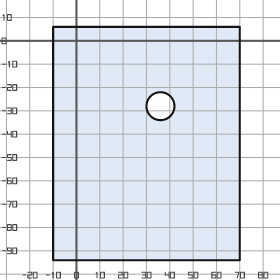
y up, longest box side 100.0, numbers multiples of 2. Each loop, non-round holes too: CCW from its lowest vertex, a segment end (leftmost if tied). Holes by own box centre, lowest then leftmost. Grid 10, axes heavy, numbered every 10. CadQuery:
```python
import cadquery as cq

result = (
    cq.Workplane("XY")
    .moveTo(-10.0, -94.0)
    .lineTo(70.0, -94.0)
    .lineTo(70.0, 6.0)
    .lineTo(-10.0, 6.0)
    .close()
    .moveTo(36.0, -28.0)
    .circle(6.0)
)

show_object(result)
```